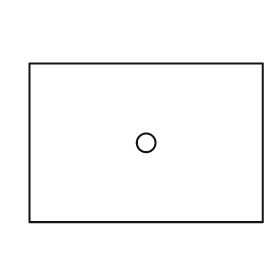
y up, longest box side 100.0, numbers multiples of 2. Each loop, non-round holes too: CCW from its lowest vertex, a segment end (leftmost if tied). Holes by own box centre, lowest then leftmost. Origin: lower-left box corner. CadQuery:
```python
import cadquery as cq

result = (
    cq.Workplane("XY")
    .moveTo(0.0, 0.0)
    .lineTo(100.0, 0.0)
    .lineTo(100.0, 68.0)
    .lineTo(0.0, 68.0)
    .close()
    .moveTo(50.0, 34.0)
    .circle(4.0)
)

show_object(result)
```